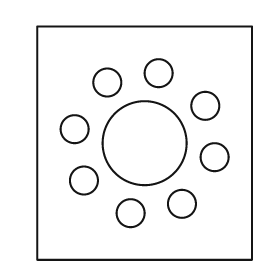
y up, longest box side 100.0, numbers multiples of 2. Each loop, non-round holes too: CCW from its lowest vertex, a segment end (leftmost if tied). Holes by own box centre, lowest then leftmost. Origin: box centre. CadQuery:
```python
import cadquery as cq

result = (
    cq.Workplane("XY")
    .moveTo(-46.0, -50.0)
    .lineTo(46.0, -50.0)
    .lineTo(46.0, 50.0)
    .lineTo(-46.0, 50.0)
    .close()
    .moveTo(-6.0, -30.0)
    .circle(6.0)
    .moveTo(16.0, -26.0)
    .circle(6.0)
    .moveTo(-26.0, -16.0)
    .circle(6.0)
    .moveTo(30.0, -6.0)
    .circle(6.0)
    .moveTo(0.0, 0.0)
    .circle(18.0)
    .moveTo(-30.0, 6.0)
    .circle(6.0)
    .moveTo(26.0, 16.0)
    .circle(6.0)
    .moveTo(-16.0, 26.0)
    .circle(6.0)
    .moveTo(6.0, 30.0)
    .circle(6.0)
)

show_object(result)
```